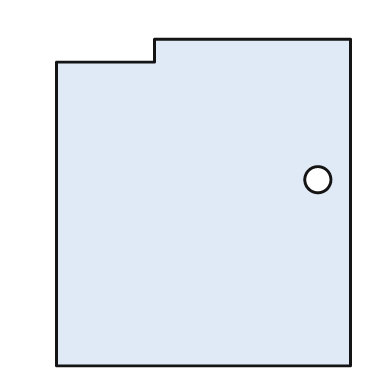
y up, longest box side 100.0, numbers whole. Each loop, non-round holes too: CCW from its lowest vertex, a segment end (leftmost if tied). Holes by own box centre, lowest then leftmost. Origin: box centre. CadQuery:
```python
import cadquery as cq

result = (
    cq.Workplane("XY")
    .moveTo(-45.0, -50.0)
    .lineTo(45.0, -50.0)
    .lineTo(45.0, 50.0)
    .lineTo(-15.0, 50.0)
    .lineTo(-15.0, 43.0)
    .lineTo(-45.0, 43.0)
    .close()
    .moveTo(35.0, 7.0)
    .circle(4.0)
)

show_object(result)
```